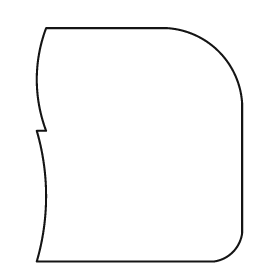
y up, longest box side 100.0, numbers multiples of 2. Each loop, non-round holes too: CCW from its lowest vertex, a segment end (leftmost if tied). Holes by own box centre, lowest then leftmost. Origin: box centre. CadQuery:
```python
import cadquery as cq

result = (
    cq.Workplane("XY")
    .moveTo(-44.0, -50.0)
    .lineTo(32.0, -50.0)
    .threePointArc((40.0, -46.0), (44.0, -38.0))
    .lineTo(44.0, 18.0)
    .threePointArc((34.0, 40.0), (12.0, 50.0))
    .lineTo(-40.0, 50.0)
    .threePointArc((-44.0, 28.0), (-40.0, 6.0))
    .lineTo(-44.0, 6.0)
    .threePointArc((-40.0, -22.0), (-44.0, -50.0))
    .close()
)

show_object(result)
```